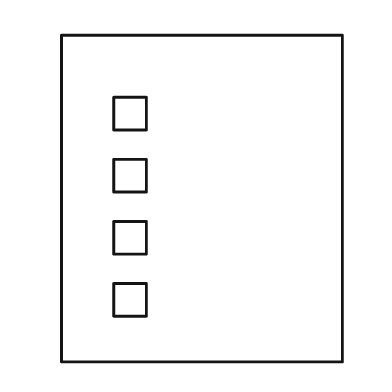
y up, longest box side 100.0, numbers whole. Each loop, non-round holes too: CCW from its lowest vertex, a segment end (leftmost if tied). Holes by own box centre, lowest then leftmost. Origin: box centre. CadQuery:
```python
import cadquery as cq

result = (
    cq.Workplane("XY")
    .moveTo(-43.0, -50.0)
    .lineTo(43.0, -50.0)
    .lineTo(43.0, 50.0)
    .lineTo(-43.0, 50.0)
    .close()
    .moveTo(-27.0, -36.0)
    .lineTo(-17.0, -36.0)
    .lineTo(-17.0, -26.0)
    .lineTo(-27.0, -26.0)
    .close()
    .moveTo(-27.0, -17.0)
    .lineTo(-17.0, -17.0)
    .lineTo(-17.0, -7.0)
    .lineTo(-27.0, -7.0)
    .close()
    .moveTo(-27.0, 2.0)
    .lineTo(-17.0, 2.0)
    .lineTo(-17.0, 12.0)
    .lineTo(-27.0, 12.0)
    .close()
    .moveTo(-27.0, 21.0)
    .lineTo(-17.0, 21.0)
    .lineTo(-17.0, 31.0)
    .lineTo(-27.0, 31.0)
    .close()
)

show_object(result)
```